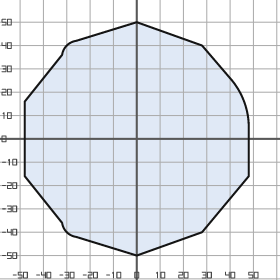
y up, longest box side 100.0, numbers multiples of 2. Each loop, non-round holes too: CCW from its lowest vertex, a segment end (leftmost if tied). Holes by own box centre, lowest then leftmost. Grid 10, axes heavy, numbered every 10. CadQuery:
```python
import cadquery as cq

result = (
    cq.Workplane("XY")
    .moveTo(0.0, -50.0)
    .lineTo(28.0, -40.0)
    .lineTo(48.0, -16.0)
    .lineTo(48.0, 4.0)
    .threePointArc((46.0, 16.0), (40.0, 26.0))
    .lineTo(28.0, 40.0)
    .lineTo(0.0, 50.0)
    .lineTo(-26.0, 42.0)
    .threePointArc((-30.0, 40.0), (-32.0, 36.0))
    .lineTo(-48.0, 16.0)
    .lineTo(-48.0, -16.0)
    .lineTo(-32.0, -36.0)
    .threePointArc((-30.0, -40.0), (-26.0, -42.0))
    .close()
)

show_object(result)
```